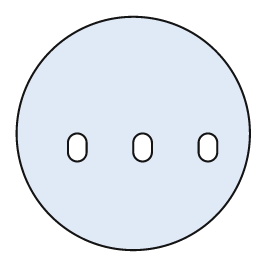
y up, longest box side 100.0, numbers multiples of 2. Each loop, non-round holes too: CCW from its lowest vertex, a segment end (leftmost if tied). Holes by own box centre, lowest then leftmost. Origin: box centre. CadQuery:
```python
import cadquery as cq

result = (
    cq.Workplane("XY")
    .moveTo(0.0, 0.0)
    .circle(50.0)
    .moveTo(-28.0, -8.0)
    .threePointArc((-24.0, -12.0), (-20.0, -8.0))
    .lineTo(-20.0, -4.0)
    .threePointArc((-24.0, 0.0), (-28.0, -4.0))
    .close()
    .moveTo(0.0, -8.0)
    .threePointArc((4.0, -12.0), (8.0, -8.0))
    .lineTo(8.0, -4.0)
    .threePointArc((4.0, 0.0), (0.0, -4.0))
    .close()
    .moveTo(28.0, -8.0)
    .threePointArc((32.0, -12.0), (36.0, -8.0))
    .lineTo(36.0, -4.0)
    .threePointArc((32.0, 0.0), (28.0, -4.0))
    .close()
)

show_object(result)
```